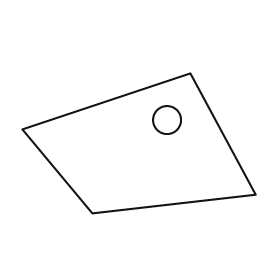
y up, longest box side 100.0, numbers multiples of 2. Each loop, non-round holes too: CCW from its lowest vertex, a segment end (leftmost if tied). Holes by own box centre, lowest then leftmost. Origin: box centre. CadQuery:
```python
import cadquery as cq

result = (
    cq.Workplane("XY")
    .moveTo(-20.0, -30.0)
    .lineTo(50.0, -22.0)
    .lineTo(22.0, 30.0)
    .lineTo(-50.0, 6.0)
    .close()
    .moveTo(12.0, 10.0)
    .circle(6.0)
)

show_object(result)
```